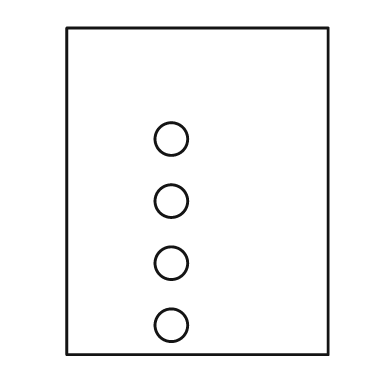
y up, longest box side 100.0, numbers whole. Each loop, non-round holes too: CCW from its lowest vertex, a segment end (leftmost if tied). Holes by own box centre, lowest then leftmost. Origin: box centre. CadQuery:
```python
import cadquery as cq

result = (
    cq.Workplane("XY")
    .moveTo(-40.0, -50.0)
    .lineTo(40.0, -50.0)
    .lineTo(40.0, 50.0)
    .lineTo(-40.0, 50.0)
    .close()
    .moveTo(-8.0, -41.0)
    .circle(5.0)
    .moveTo(-8.0, -22.0)
    .circle(5.0)
    .moveTo(-8.0, -3.0)
    .circle(5.0)
    .moveTo(-8.0, 16.0)
    .circle(5.0)
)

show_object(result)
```